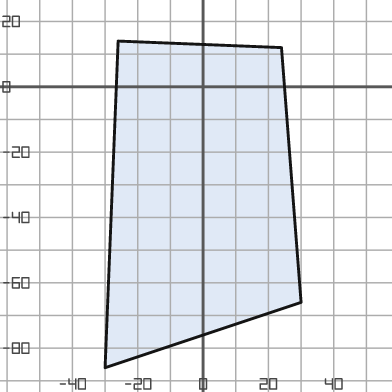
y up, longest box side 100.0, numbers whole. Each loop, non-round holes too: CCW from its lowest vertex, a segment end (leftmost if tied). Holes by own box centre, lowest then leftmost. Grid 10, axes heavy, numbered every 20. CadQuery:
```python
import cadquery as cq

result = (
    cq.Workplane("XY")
    .moveTo(-30.0, -86.0)
    .lineTo(30.0, -66.0)
    .lineTo(24.0, 12.0)
    .lineTo(-26.0, 14.0)
    .close()
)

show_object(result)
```